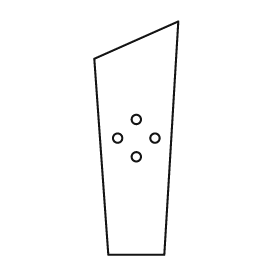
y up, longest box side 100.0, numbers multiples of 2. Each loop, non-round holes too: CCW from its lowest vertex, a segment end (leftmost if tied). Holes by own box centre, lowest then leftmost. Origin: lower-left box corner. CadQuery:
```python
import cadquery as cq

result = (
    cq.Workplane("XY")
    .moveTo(6.0, 0.0)
    .lineTo(30.0, 0.0)
    .lineTo(36.0, 100.0)
    .lineTo(0.0, 84.0)
    .close()
    .moveTo(18.0, 42.0)
    .circle(2.0)
    .moveTo(10.0, 50.0)
    .circle(2.0)
    .moveTo(26.0, 50.0)
    .circle(2.0)
    .moveTo(18.0, 58.0)
    .circle(2.0)
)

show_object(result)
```